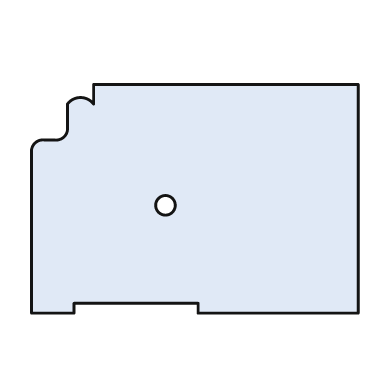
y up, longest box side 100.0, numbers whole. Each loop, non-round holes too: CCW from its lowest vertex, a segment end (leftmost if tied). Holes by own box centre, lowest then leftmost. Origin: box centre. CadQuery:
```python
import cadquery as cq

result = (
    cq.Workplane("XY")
    .moveTo(-50.0, -35.0)
    .lineTo(-37.0, -35.0)
    .lineTo(-37.0, -32.0)
    .lineTo(1.0, -32.0)
    .lineTo(1.0, -35.0)
    .lineTo(50.0, -35.0)
    .lineTo(50.0, 35.0)
    .lineTo(-31.0, 35.0)
    .lineTo(-31.0, 29.0)
    .threePointArc((-35.0, 31.0), (-39.0, 29.0))
    .lineTo(-39.0, 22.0)
    .threePointArc((-40.0, 19.0), (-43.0, 18.0))
    .lineTo(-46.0, 18.0)
    .threePointArc((-49.0, 17.0), (-50.0, 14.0))
    .close()
    .moveTo(-9.0, -2.0)
    .circle(3.0)
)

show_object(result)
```